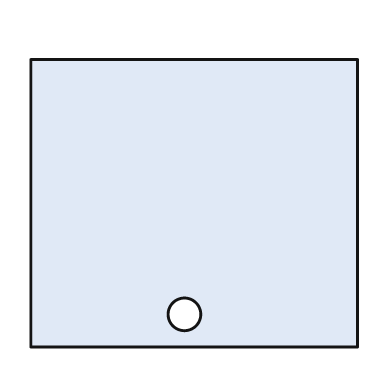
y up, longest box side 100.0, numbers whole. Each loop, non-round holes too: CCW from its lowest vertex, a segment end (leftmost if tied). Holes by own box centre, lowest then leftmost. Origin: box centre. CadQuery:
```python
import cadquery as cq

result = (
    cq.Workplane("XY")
    .moveTo(-50.0, -44.0)
    .lineTo(50.0, -44.0)
    .lineTo(50.0, 44.0)
    .lineTo(-50.0, 44.0)
    .close()
    .moveTo(-3.0, -34.0)
    .circle(5.0)
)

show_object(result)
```